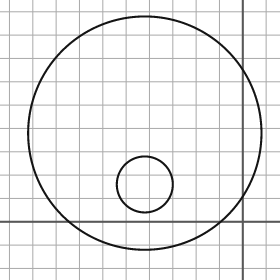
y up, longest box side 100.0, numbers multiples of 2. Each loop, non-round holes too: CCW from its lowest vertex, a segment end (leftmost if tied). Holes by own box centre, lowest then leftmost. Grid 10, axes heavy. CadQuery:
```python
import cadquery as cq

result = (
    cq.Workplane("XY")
    .moveTo(-42.0, 38.0)
    .circle(50.0)
    .moveTo(-42.0, 16.0)
    .circle(12.0)
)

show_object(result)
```